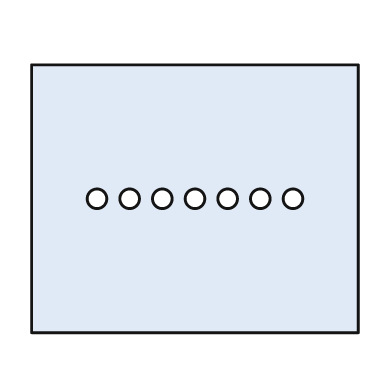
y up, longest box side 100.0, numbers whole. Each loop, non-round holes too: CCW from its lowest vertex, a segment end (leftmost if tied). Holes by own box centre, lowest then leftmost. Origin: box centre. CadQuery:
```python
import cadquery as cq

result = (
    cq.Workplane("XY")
    .moveTo(-50.0, -41.0)
    .lineTo(50.0, -41.0)
    .lineTo(50.0, 41.0)
    .lineTo(-50.0, 41.0)
    .close()
    .moveTo(-30.0, 0.0)
    .circle(3.0)
    .moveTo(-20.0, 0.0)
    .circle(3.0)
    .moveTo(-10.0, 0.0)
    .circle(3.0)
    .moveTo(0.0, 0.0)
    .circle(3.0)
    .moveTo(10.0, 0.0)
    .circle(3.0)
    .moveTo(20.0, 0.0)
    .circle(3.0)
    .moveTo(30.0, 0.0)
    .circle(3.0)
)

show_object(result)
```